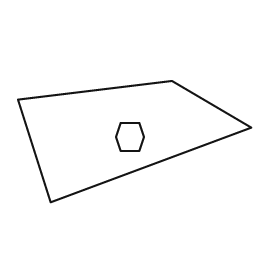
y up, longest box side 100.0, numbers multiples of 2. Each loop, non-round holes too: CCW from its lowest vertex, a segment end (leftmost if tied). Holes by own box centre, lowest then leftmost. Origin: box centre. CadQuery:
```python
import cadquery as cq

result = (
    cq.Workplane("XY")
    .moveTo(-36.0, -26.0)
    .lineTo(50.0, 6.0)
    .lineTo(16.0, 26.0)
    .lineTo(-50.0, 18.0)
    .close()
    .moveTo(-6.0, -4.0)
    .lineTo(2.0, -4.0)
    .lineTo(4.0, 2.0)
    .lineTo(2.0, 8.0)
    .lineTo(-6.0, 8.0)
    .lineTo(-8.0, 2.0)
    .close()
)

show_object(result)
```